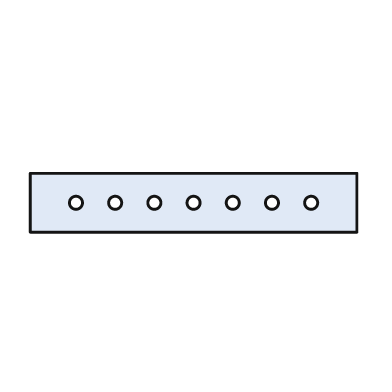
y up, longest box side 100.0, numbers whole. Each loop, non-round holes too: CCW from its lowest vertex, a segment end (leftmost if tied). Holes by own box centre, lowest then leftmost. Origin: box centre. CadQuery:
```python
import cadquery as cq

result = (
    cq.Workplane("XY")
    .moveTo(-50.0, -9.0)
    .lineTo(50.0, -9.0)
    .lineTo(50.0, 9.0)
    .lineTo(-50.0, 9.0)
    .close()
    .moveTo(-36.0, 0.0)
    .circle(2.0)
    .moveTo(-24.0, 0.0)
    .circle(2.0)
    .moveTo(-12.0, 0.0)
    .circle(2.0)
    .moveTo(0.0, 0.0)
    .circle(2.0)
    .moveTo(12.0, 0.0)
    .circle(2.0)
    .moveTo(24.0, 0.0)
    .circle(2.0)
    .moveTo(36.0, 0.0)
    .circle(2.0)
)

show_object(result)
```